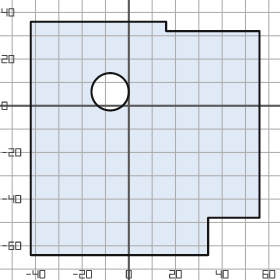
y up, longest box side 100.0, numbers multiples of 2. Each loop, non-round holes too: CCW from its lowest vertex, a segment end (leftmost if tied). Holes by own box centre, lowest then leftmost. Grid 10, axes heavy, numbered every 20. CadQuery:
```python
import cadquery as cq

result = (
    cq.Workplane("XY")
    .moveTo(-42.0, -64.0)
    .lineTo(34.0, -64.0)
    .lineTo(34.0, -48.0)
    .lineTo(56.0, -48.0)
    .lineTo(56.0, 32.0)
    .lineTo(16.0, 32.0)
    .lineTo(16.0, 36.0)
    .lineTo(-42.0, 36.0)
    .close()
    .moveTo(-8.0, 6.0)
    .circle(8.0)
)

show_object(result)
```